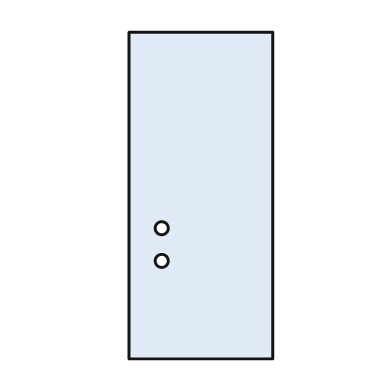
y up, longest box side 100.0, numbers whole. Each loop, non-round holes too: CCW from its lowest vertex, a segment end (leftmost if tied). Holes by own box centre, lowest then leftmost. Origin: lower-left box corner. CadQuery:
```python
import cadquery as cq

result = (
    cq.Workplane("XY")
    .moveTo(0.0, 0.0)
    .lineTo(44.0, 0.0)
    .lineTo(44.0, 100.0)
    .lineTo(0.0, 100.0)
    .close()
    .moveTo(10.0, 30.0)
    .circle(2.0)
    .moveTo(10.0, 40.0)
    .circle(2.0)
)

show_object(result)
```